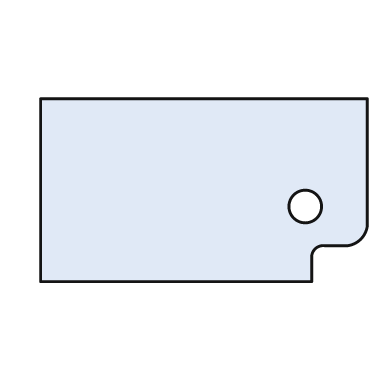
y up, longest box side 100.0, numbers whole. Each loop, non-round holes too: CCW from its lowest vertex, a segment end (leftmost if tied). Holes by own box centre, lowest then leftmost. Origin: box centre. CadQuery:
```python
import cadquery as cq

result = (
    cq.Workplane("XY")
    .moveTo(-50.0, -28.0)
    .lineTo(33.0, -28.0)
    .lineTo(33.0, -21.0)
    .threePointArc((34.0, -18.0), (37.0, -17.0))
    .lineTo(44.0, -17.0)
    .threePointArc((48.0, -15.0), (50.0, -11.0))
    .lineTo(50.0, 28.0)
    .lineTo(-50.0, 28.0)
    .close()
    .moveTo(31.0, -5.0)
    .circle(5.0)
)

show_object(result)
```